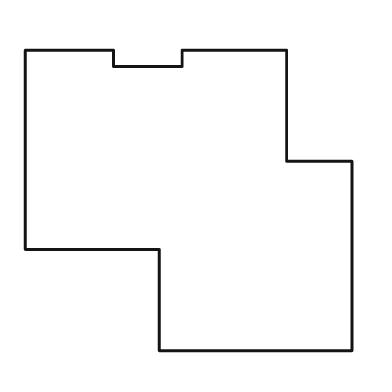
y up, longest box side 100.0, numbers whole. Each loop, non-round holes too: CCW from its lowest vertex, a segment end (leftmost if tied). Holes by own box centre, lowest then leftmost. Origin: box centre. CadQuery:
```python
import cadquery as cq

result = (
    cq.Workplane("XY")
    .moveTo(-9.0, -46.0)
    .lineTo(50.0, -46.0)
    .lineTo(50.0, 12.0)
    .lineTo(30.0, 12.0)
    .lineTo(30.0, 46.0)
    .lineTo(-2.0, 46.0)
    .lineTo(-2.0, 41.0)
    .lineTo(-23.0, 41.0)
    .lineTo(-23.0, 46.0)
    .lineTo(-50.0, 46.0)
    .lineTo(-50.0, -15.0)
    .lineTo(-9.0, -15.0)
    .close()
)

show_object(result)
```